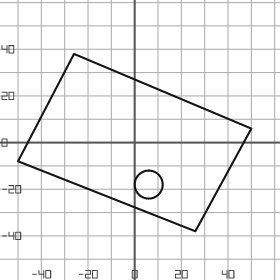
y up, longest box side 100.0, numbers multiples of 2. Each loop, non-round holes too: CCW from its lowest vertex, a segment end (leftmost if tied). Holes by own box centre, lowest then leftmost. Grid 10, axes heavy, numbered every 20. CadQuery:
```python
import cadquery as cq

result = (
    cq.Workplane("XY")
    .moveTo(26.0, -38.0)
    .lineTo(50.0, 6.0)
    .lineTo(-26.0, 38.0)
    .lineTo(-50.0, -8.0)
    .close()
    .moveTo(6.0, -18.0)
    .circle(6.0)
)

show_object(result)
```